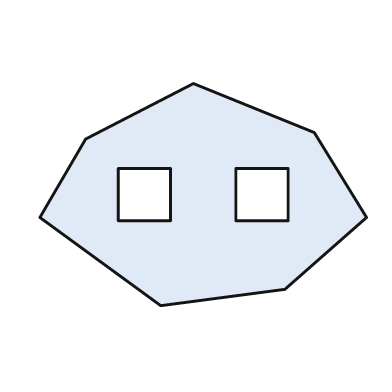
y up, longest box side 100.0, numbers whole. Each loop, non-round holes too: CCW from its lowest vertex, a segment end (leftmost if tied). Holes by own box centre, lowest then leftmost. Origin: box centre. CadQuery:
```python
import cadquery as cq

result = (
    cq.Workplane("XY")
    .moveTo(-13.0, -34.0)
    .lineTo(25.0, -29.0)
    .lineTo(50.0, -7.0)
    .lineTo(34.0, 19.0)
    .lineTo(-3.0, 34.0)
    .lineTo(-36.0, 17.0)
    .lineTo(-50.0, -7.0)
    .close()
    .moveTo(-26.0, -8.0)
    .lineTo(-10.0, -8.0)
    .lineTo(-10.0, 8.0)
    .lineTo(-26.0, 8.0)
    .close()
    .moveTo(10.0, -8.0)
    .lineTo(26.0, -8.0)
    .lineTo(26.0, 8.0)
    .lineTo(10.0, 8.0)
    .close()
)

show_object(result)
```